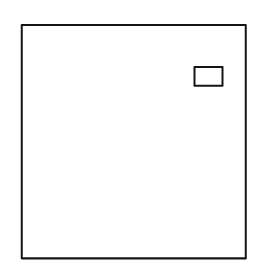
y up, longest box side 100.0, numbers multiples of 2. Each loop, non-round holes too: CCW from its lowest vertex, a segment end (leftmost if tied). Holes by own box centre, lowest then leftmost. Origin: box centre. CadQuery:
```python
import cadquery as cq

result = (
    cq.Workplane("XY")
    .moveTo(-48.0, -50.0)
    .lineTo(48.0, -50.0)
    .lineTo(48.0, 50.0)
    .lineTo(-48.0, 50.0)
    .close()
    .moveTo(26.0, 24.0)
    .lineTo(38.0, 24.0)
    .lineTo(38.0, 32.0)
    .lineTo(26.0, 32.0)
    .close()
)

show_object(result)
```